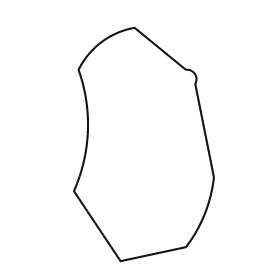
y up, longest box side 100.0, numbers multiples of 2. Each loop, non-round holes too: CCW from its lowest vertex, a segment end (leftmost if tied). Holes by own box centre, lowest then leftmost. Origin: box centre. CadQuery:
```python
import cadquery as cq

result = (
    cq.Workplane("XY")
    .moveTo(-10.0, -50.0)
    .lineTo(18.0, -44.0)
    .threePointArc((26.0, -30.0), (30.0, -14.0))
    .lineTo(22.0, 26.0)
    .threePointArc((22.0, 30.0), (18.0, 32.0))
    .lineTo(-4.0, 50.0)
    .threePointArc((-18.0, 44.0), (-28.0, 32.0))
    .threePointArc((-24.0, 6.0), (-30.0, -20.0))
    .close()
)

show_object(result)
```